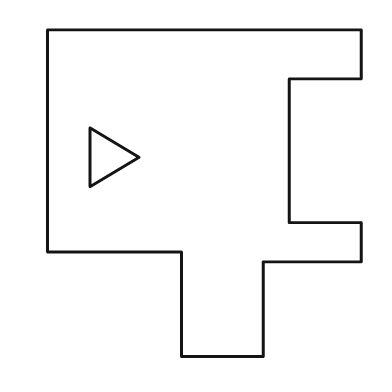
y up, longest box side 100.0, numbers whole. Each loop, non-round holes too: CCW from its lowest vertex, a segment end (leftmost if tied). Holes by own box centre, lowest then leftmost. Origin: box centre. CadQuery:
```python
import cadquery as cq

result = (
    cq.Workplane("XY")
    .moveTo(-7.0, -50.0)
    .lineTo(18.0, -50.0)
    .lineTo(18.0, -21.0)
    .lineTo(48.0, -21.0)
    .lineTo(48.0, -9.0)
    .lineTo(26.0, -9.0)
    .lineTo(26.0, 35.0)
    .lineTo(48.0, 35.0)
    .lineTo(48.0, 50.0)
    .lineTo(-48.0, 50.0)
    .lineTo(-48.0, -18.0)
    .lineTo(-7.0, -18.0)
    .close()
    .moveTo(-35.0, 2.0)
    .lineTo(-20.0, 11.0)
    .lineTo(-35.0, 20.0)
    .close()
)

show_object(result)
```